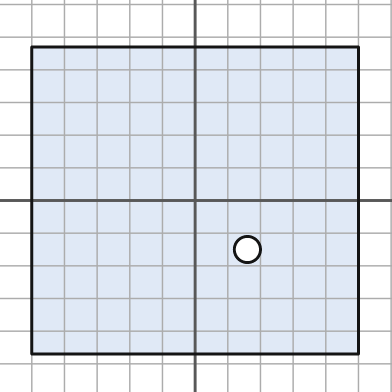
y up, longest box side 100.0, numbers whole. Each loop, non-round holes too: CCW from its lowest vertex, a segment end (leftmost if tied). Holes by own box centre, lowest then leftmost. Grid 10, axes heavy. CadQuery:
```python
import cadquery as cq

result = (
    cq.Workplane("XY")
    .moveTo(-50.0, -47.0)
    .lineTo(50.0, -47.0)
    .lineTo(50.0, 47.0)
    .lineTo(-50.0, 47.0)
    .close()
    .moveTo(16.0, -15.0)
    .circle(4.0)
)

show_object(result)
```